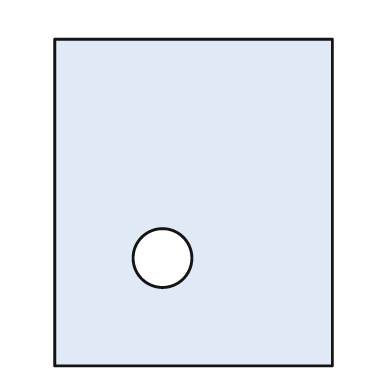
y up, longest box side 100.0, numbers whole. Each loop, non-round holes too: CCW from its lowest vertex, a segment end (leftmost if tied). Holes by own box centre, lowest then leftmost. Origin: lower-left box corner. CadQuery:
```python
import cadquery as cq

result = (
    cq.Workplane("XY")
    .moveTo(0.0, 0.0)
    .lineTo(85.0, 0.0)
    .lineTo(85.0, 100.0)
    .lineTo(0.0, 100.0)
    .close()
    .moveTo(33.0, 33.0)
    .circle(9.0)
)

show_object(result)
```